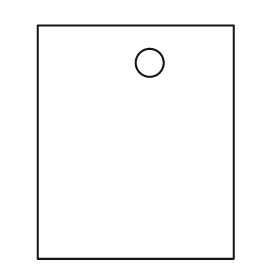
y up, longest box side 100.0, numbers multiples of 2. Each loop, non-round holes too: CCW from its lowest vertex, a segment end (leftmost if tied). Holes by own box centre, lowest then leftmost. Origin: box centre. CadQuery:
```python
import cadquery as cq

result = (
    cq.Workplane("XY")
    .moveTo(-42.0, -50.0)
    .lineTo(42.0, -50.0)
    .lineTo(42.0, 50.0)
    .lineTo(-42.0, 50.0)
    .close()
    .moveTo(6.0, 34.0)
    .circle(6.0)
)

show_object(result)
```